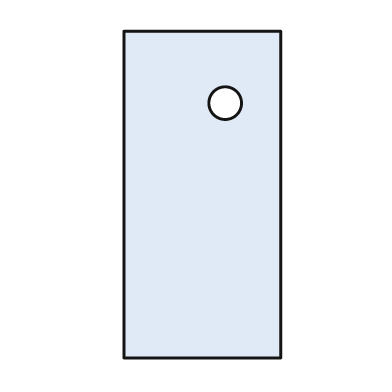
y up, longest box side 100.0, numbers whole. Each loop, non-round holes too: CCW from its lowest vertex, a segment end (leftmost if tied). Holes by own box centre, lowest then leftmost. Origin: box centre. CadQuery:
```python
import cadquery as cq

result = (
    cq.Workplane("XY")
    .moveTo(-24.0, -50.0)
    .lineTo(24.0, -50.0)
    .lineTo(24.0, 50.0)
    .lineTo(-24.0, 50.0)
    .close()
    .moveTo(7.0, 28.0)
    .circle(5.0)
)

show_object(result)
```